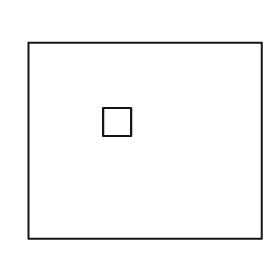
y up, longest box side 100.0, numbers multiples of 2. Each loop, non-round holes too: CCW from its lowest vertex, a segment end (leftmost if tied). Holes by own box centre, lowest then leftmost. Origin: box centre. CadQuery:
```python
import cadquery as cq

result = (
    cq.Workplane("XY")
    .moveTo(-50.0, -42.0)
    .lineTo(50.0, -42.0)
    .lineTo(50.0, 42.0)
    .lineTo(-50.0, 42.0)
    .close()
    .moveTo(-18.0, 2.0)
    .lineTo(-6.0, 2.0)
    .lineTo(-6.0, 14.0)
    .lineTo(-18.0, 14.0)
    .close()
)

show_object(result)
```